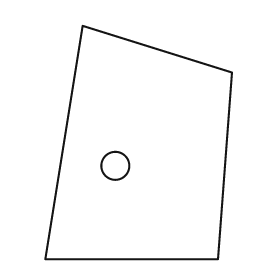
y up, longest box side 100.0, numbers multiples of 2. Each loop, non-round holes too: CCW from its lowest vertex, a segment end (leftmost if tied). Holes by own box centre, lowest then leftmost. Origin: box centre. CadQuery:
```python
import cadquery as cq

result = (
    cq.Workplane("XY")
    .moveTo(-40.0, -50.0)
    .lineTo(34.0, -50.0)
    .lineTo(40.0, 30.0)
    .lineTo(-24.0, 50.0)
    .close()
    .moveTo(-10.0, -10.0)
    .circle(6.0)
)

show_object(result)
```